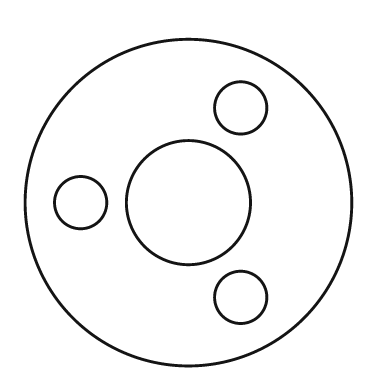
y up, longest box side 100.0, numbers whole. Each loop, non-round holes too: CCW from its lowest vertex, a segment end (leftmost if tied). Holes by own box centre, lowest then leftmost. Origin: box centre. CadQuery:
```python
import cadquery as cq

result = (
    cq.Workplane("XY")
    .moveTo(0.0, 0.0)
    .circle(50.0)
    .moveTo(16.0, -29.0)
    .circle(8.0)
    .moveTo(-33.0, 0.0)
    .circle(8.0)
    .moveTo(0.0, 0.0)
    .circle(19.0)
    .moveTo(16.0, 29.0)
    .circle(8.0)
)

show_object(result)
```